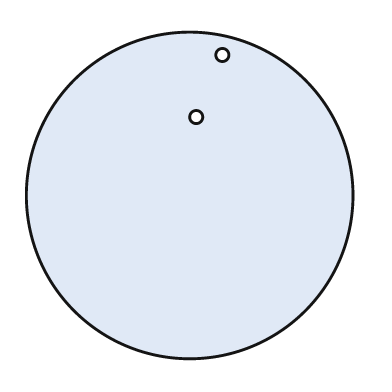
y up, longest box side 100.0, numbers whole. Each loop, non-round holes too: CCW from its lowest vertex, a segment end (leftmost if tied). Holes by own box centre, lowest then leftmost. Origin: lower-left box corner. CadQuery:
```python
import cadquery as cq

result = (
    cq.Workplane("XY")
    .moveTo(50.0, 50.0)
    .circle(50.0)
    .moveTo(52.0, 74.0)
    .circle(2.0)
    .moveTo(60.0, 93.0)
    .circle(2.0)
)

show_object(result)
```